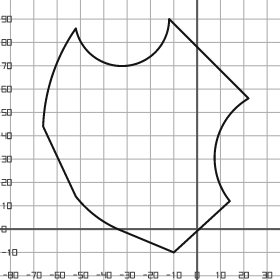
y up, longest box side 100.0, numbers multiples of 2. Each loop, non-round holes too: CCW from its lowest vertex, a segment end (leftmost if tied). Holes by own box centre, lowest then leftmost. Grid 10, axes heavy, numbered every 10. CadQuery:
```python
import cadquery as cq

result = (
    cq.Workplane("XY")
    .moveTo(-10.0, -10.0)
    .lineTo(14.0, 12.0)
    .threePointArc((8.0, 36.0), (22.0, 56.0))
    .lineTo(-12.0, 90.0)
    .threePointArc((-30.0, 70.0), (-52.0, 86.0))
    .threePointArc((-62.0, 66.0), (-66.0, 44.0))
    .lineTo(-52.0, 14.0)
    .threePointArc((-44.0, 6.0), (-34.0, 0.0))
    .close()
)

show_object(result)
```